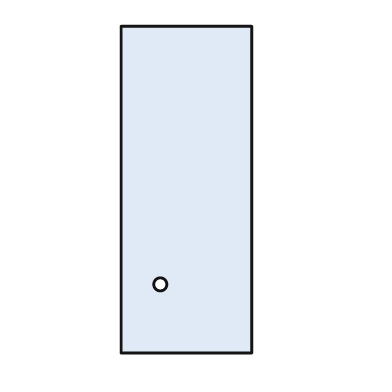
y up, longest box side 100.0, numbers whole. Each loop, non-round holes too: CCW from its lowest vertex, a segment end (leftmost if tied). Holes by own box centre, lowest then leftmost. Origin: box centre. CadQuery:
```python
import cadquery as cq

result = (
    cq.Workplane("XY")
    .moveTo(-20.0, -50.0)
    .lineTo(20.0, -50.0)
    .lineTo(20.0, 50.0)
    .lineTo(-20.0, 50.0)
    .close()
    .moveTo(-8.0, -29.0)
    .circle(2.0)
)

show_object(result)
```